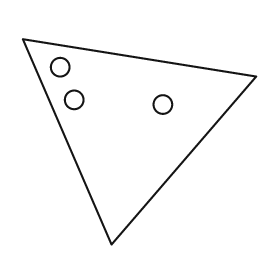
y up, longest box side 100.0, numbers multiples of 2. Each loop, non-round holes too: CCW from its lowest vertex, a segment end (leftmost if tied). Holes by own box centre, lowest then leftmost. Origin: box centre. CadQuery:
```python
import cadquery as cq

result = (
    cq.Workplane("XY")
    .moveTo(-12.0, -44.0)
    .lineTo(50.0, 28.0)
    .lineTo(-50.0, 44.0)
    .close()
    .moveTo(10.0, 16.0)
    .circle(4.0)
    .moveTo(-28.0, 18.0)
    .circle(4.0)
    .moveTo(-34.0, 32.0)
    .circle(4.0)
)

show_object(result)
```